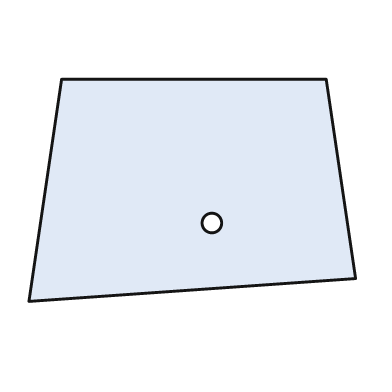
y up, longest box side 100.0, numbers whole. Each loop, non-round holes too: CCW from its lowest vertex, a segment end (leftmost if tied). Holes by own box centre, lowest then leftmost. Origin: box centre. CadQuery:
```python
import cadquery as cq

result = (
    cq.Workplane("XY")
    .moveTo(-50.0, -34.0)
    .lineTo(50.0, -27.0)
    .lineTo(41.0, 34.0)
    .lineTo(-40.0, 34.0)
    .close()
    .moveTo(6.0, -10.0)
    .circle(3.0)
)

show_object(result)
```